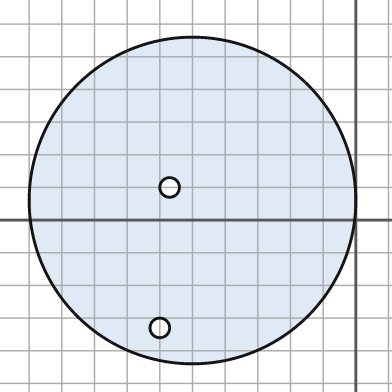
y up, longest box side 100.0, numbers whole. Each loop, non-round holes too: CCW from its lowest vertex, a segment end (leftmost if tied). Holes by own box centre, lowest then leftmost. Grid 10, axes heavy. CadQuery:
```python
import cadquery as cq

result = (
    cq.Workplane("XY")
    .moveTo(-50.0, 6.0)
    .circle(50.0)
    .moveTo(-60.0, -33.0)
    .circle(3.0)
    .moveTo(-57.0, 10.0)
    .circle(3.0)
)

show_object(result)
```